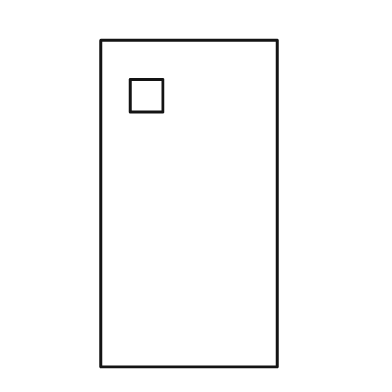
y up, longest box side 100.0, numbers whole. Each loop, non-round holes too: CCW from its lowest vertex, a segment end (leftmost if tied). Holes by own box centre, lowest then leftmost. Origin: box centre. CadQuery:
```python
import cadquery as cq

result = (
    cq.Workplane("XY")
    .moveTo(-27.0, -50.0)
    .lineTo(27.0, -50.0)
    .lineTo(27.0, 50.0)
    .lineTo(-27.0, 50.0)
    .close()
    .moveTo(-18.0, 28.0)
    .lineTo(-8.0, 28.0)
    .lineTo(-8.0, 38.0)
    .lineTo(-18.0, 38.0)
    .close()
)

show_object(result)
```